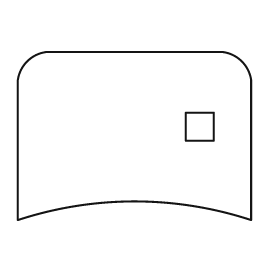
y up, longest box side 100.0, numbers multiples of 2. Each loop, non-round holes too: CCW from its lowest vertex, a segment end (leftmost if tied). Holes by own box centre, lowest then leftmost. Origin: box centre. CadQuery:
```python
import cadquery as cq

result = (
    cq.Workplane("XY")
    .moveTo(-50.0, -36.0)
    .threePointArc((0.0, -28.0), (50.0, -36.0))
    .lineTo(50.0, 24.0)
    .threePointArc((46.0, 32.0), (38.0, 36.0))
    .lineTo(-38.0, 36.0)
    .threePointArc((-46.0, 32.0), (-50.0, 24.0))
    .close()
    .moveTo(22.0, -2.0)
    .lineTo(34.0, -2.0)
    .lineTo(34.0, 10.0)
    .lineTo(22.0, 10.0)
    .close()
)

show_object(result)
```